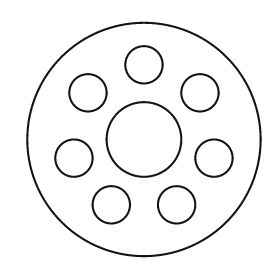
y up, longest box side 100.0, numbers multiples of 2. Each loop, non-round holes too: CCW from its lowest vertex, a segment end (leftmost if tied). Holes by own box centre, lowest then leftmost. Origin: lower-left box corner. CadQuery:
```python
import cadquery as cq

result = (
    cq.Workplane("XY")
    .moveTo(50.0, 50.0)
    .circle(50.0)
    .moveTo(36.0, 22.0)
    .circle(8.0)
    .moveTo(64.0, 22.0)
    .circle(8.0)
    .moveTo(20.0, 42.0)
    .circle(8.0)
    .moveTo(80.0, 42.0)
    .circle(8.0)
    .moveTo(50.0, 50.0)
    .circle(16.0)
    .moveTo(26.0, 70.0)
    .circle(8.0)
    .moveTo(74.0, 70.0)
    .circle(8.0)
    .moveTo(50.0, 82.0)
    .circle(8.0)
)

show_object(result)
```